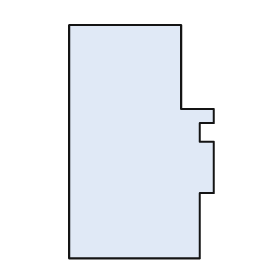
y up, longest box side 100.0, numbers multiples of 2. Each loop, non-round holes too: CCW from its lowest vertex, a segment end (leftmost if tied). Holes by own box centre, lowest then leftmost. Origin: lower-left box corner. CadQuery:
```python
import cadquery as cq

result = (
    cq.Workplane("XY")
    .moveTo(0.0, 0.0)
    .lineTo(56.0, 0.0)
    .lineTo(56.0, 28.0)
    .lineTo(62.0, 28.0)
    .lineTo(62.0, 50.0)
    .lineTo(56.0, 50.0)
    .lineTo(56.0, 58.0)
    .lineTo(62.0, 58.0)
    .lineTo(62.0, 64.0)
    .lineTo(48.0, 64.0)
    .lineTo(48.0, 100.0)
    .lineTo(0.0, 100.0)
    .close()
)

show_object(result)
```